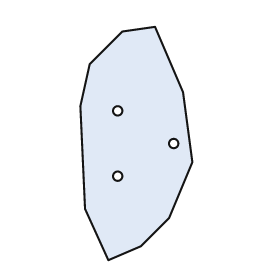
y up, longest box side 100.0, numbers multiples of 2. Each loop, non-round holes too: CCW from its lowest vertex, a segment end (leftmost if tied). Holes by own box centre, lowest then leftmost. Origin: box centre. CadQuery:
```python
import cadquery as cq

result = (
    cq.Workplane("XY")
    .moveTo(-12.0, -50.0)
    .lineTo(2.0, -44.0)
    .lineTo(14.0, -32.0)
    .lineTo(24.0, -8.0)
    .lineTo(20.0, 22.0)
    .lineTo(8.0, 50.0)
    .lineTo(-6.0, 48.0)
    .lineTo(-20.0, 34.0)
    .lineTo(-24.0, 16.0)
    .lineTo(-22.0, -28.0)
    .close()
    .moveTo(-8.0, -14.0)
    .circle(2.0)
    .moveTo(16.0, 0.0)
    .circle(2.0)
    .moveTo(-8.0, 14.0)
    .circle(2.0)
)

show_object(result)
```